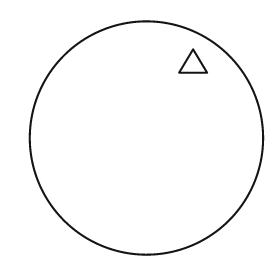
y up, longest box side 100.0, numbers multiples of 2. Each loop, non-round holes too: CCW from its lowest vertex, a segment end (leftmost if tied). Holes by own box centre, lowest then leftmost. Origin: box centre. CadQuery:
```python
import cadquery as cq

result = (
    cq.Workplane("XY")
    .moveTo(0.0, 0.0)
    .circle(50.0)
    .moveTo(14.0, 28.0)
    .lineTo(26.0, 28.0)
    .lineTo(20.0, 38.0)
    .close()
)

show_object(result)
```